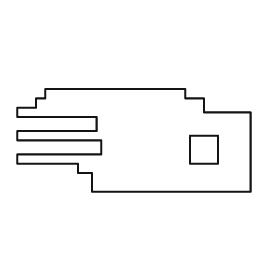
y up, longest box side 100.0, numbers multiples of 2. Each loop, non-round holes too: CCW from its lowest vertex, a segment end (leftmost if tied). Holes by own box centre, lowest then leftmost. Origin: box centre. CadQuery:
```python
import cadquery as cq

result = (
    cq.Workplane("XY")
    .moveTo(-18.0, -22.0)
    .lineTo(50.0, -22.0)
    .lineTo(50.0, 12.0)
    .lineTo(30.0, 12.0)
    .lineTo(30.0, 18.0)
    .lineTo(22.0, 18.0)
    .lineTo(22.0, 22.0)
    .lineTo(-38.0, 22.0)
    .lineTo(-38.0, 18.0)
    .lineTo(-42.0, 18.0)
    .lineTo(-42.0, 14.0)
    .lineTo(-50.0, 14.0)
    .lineTo(-50.0, 10.0)
    .lineTo(-16.0, 10.0)
    .lineTo(-16.0, 4.0)
    .lineTo(-50.0, 4.0)
    .lineTo(-50.0, 0.0)
    .lineTo(-14.0, 0.0)
    .lineTo(-14.0, -6.0)
    .lineTo(-50.0, -6.0)
    .lineTo(-50.0, -10.0)
    .lineTo(-24.0, -10.0)
    .lineTo(-24.0, -14.0)
    .lineTo(-18.0, -14.0)
    .close()
    .moveTo(24.0, -10.0)
    .lineTo(36.0, -10.0)
    .lineTo(36.0, 2.0)
    .lineTo(24.0, 2.0)
    .close()
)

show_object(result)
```